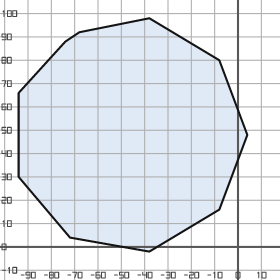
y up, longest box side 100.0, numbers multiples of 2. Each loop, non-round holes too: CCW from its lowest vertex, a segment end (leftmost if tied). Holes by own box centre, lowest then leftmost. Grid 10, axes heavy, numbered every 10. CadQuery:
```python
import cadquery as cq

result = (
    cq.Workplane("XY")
    .moveTo(-38.0, -2.0)
    .lineTo(-8.0, 16.0)
    .lineTo(4.0, 48.0)
    .lineTo(-8.0, 80.0)
    .lineTo(-38.0, 98.0)
    .lineTo(-68.0, 92.0)
    .lineTo(-74.0, 88.0)
    .lineTo(-94.0, 66.0)
    .lineTo(-94.0, 30.0)
    .lineTo(-72.0, 4.0)
    .close()
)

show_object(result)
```